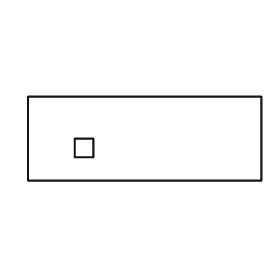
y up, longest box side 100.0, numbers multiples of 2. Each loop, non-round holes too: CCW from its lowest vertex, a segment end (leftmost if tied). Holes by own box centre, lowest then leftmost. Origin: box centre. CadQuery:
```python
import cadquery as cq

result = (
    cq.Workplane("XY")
    .moveTo(-50.0, -18.0)
    .lineTo(50.0, -18.0)
    .lineTo(50.0, 18.0)
    .lineTo(-50.0, 18.0)
    .close()
    .moveTo(-30.0, -8.0)
    .lineTo(-22.0, -8.0)
    .lineTo(-22.0, 0.0)
    .lineTo(-30.0, 0.0)
    .close()
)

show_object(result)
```